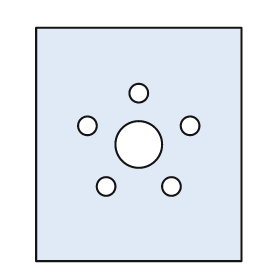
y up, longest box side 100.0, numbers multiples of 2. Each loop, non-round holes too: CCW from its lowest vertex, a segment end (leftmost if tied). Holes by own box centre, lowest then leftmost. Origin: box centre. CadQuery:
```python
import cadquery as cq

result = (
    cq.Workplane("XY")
    .moveTo(-44.0, -50.0)
    .lineTo(44.0, -50.0)
    .lineTo(44.0, 50.0)
    .lineTo(-44.0, 50.0)
    .close()
    .moveTo(-14.0, -18.0)
    .circle(4.0)
    .moveTo(14.0, -18.0)
    .circle(4.0)
    .moveTo(0.0, 0.0)
    .circle(10.0)
    .moveTo(-22.0, 8.0)
    .circle(4.0)
    .moveTo(22.0, 8.0)
    .circle(4.0)
    .moveTo(0.0, 22.0)
    .circle(4.0)
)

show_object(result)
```